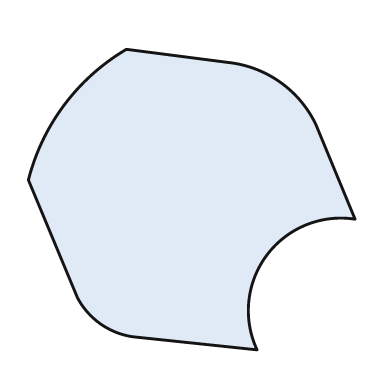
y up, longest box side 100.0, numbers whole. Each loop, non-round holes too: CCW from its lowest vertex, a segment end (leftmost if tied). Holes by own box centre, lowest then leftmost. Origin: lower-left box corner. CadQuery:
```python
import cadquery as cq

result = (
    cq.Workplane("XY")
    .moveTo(70.0, 0.0)
    .threePointArc((73.0, 29.0), (100.0, 40.0))
    .lineTo(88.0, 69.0)
    .threePointArc((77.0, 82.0), (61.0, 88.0))
    .lineTo(30.0, 92.0)
    .threePointArc((11.0, 75.0), (0.0, 52.0))
    .lineTo(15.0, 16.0)
    .threePointArc((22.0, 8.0), (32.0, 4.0))
    .close()
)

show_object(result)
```